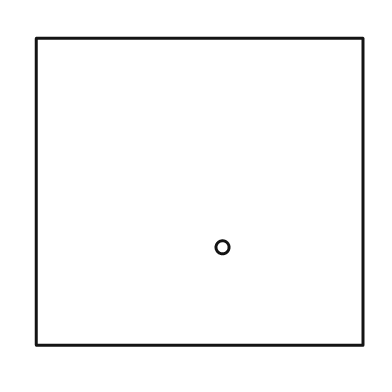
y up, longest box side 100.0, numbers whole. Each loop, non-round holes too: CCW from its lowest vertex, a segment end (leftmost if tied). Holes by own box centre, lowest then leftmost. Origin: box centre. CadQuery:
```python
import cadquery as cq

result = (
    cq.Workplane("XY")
    .moveTo(-50.0, -47.0)
    .lineTo(50.0, -47.0)
    .lineTo(50.0, 47.0)
    .lineTo(-50.0, 47.0)
    .close()
    .moveTo(7.0, -17.0)
    .circle(2.0)
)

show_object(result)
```